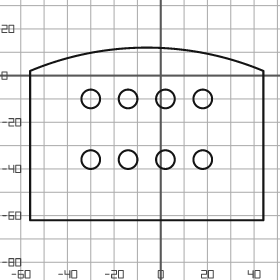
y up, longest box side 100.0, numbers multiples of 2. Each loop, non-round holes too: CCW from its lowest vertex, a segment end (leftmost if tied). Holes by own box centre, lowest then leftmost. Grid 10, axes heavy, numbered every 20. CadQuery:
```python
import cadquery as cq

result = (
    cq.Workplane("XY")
    .moveTo(-56.0, -62.0)
    .lineTo(44.0, -62.0)
    .lineTo(44.0, 2.0)
    .threePointArc((-6.0, 12.0), (-56.0, 2.0))
    .close()
    .moveTo(-30.0, -36.0)
    .circle(4.0)
    .moveTo(-14.0, -36.0)
    .circle(4.0)
    .moveTo(2.0, -36.0)
    .circle(4.0)
    .moveTo(18.0, -36.0)
    .circle(4.0)
    .moveTo(-30.0, -10.0)
    .circle(4.0)
    .moveTo(-14.0, -10.0)
    .circle(4.0)
    .moveTo(2.0, -10.0)
    .circle(4.0)
    .moveTo(18.0, -10.0)
    .circle(4.0)
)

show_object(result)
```